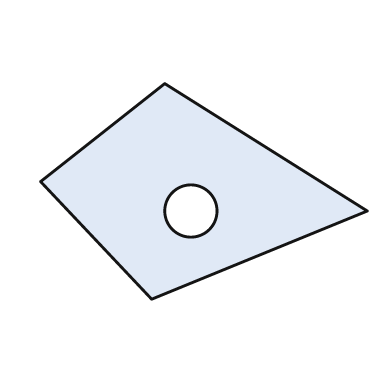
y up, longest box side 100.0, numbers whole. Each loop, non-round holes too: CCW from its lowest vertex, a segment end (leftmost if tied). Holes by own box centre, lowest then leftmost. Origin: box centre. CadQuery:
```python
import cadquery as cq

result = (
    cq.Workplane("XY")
    .moveTo(-16.0, -33.0)
    .lineTo(50.0, -6.0)
    .lineTo(-12.0, 33.0)
    .lineTo(-50.0, 3.0)
    .close()
    .moveTo(-4.0, -6.0)
    .circle(8.0)
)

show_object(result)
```